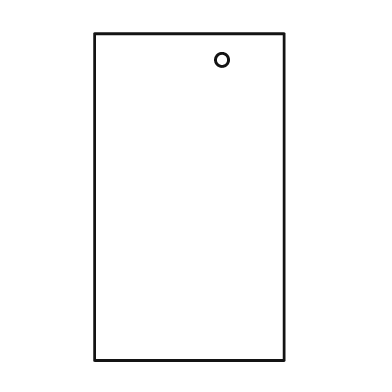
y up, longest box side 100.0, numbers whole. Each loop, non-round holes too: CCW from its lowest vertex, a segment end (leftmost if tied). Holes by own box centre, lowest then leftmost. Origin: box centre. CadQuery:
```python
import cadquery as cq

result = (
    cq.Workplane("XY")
    .moveTo(-29.0, -50.0)
    .lineTo(29.0, -50.0)
    .lineTo(29.0, 50.0)
    .lineTo(-29.0, 50.0)
    .close()
    .moveTo(10.0, 42.0)
    .circle(2.0)
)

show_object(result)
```